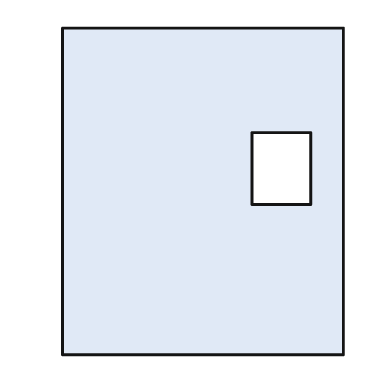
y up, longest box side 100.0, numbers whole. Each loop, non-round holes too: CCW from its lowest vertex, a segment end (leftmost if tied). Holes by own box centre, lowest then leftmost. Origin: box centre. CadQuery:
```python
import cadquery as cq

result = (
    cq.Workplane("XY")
    .moveTo(-43.0, -50.0)
    .lineTo(43.0, -50.0)
    .lineTo(43.0, 50.0)
    .lineTo(-43.0, 50.0)
    .close()
    .moveTo(15.0, -4.0)
    .lineTo(33.0, -4.0)
    .lineTo(33.0, 18.0)
    .lineTo(15.0, 18.0)
    .close()
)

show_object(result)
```